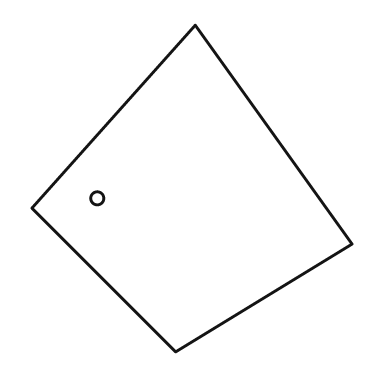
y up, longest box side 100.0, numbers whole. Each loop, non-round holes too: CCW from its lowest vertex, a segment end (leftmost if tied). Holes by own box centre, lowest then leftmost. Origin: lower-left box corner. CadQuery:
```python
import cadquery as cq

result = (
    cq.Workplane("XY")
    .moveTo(44.0, 0.0)
    .lineTo(98.0, 33.0)
    .lineTo(50.0, 100.0)
    .lineTo(0.0, 44.0)
    .close()
    .moveTo(20.0, 47.0)
    .circle(2.0)
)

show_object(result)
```